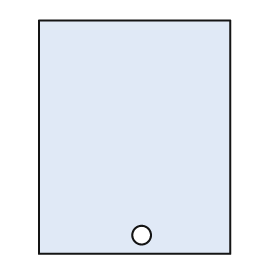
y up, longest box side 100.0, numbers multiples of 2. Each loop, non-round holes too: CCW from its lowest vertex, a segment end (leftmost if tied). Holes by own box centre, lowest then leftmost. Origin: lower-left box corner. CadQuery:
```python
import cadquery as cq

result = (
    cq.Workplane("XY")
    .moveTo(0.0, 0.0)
    .lineTo(82.0, 0.0)
    .lineTo(82.0, 100.0)
    .lineTo(0.0, 100.0)
    .close()
    .moveTo(44.0, 8.0)
    .circle(4.0)
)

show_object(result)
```